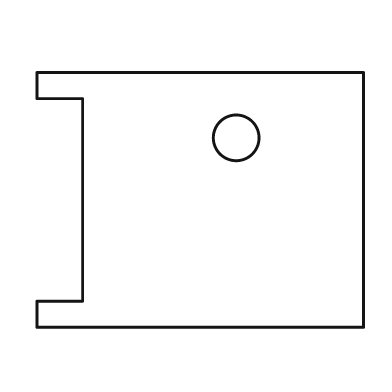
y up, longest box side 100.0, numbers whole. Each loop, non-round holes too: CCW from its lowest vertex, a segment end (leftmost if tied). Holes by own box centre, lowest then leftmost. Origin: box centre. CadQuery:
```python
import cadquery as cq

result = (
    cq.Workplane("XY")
    .moveTo(-50.0, -39.0)
    .lineTo(50.0, -39.0)
    .lineTo(50.0, 39.0)
    .lineTo(-50.0, 39.0)
    .lineTo(-50.0, 31.0)
    .lineTo(-36.0, 31.0)
    .lineTo(-36.0, -31.0)
    .lineTo(-50.0, -31.0)
    .close()
    .moveTo(11.0, 19.0)
    .circle(7.0)
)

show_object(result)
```